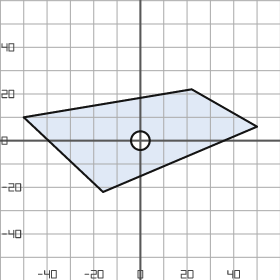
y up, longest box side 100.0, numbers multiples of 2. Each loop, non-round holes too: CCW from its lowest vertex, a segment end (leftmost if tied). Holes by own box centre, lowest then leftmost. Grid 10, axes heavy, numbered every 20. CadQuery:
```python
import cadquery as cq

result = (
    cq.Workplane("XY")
    .moveTo(-16.0, -22.0)
    .lineTo(50.0, 6.0)
    .lineTo(22.0, 22.0)
    .lineTo(-50.0, 10.0)
    .close()
    .moveTo(0.0, 0.0)
    .circle(4.0)
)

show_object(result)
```